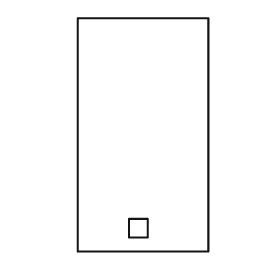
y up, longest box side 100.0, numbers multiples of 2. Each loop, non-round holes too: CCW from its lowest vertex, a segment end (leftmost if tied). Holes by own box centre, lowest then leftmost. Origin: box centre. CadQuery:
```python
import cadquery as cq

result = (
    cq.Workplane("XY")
    .moveTo(-28.0, -50.0)
    .lineTo(28.0, -50.0)
    .lineTo(28.0, 50.0)
    .lineTo(-28.0, 50.0)
    .close()
    .moveTo(-6.0, -44.0)
    .lineTo(2.0, -44.0)
    .lineTo(2.0, -36.0)
    .lineTo(-6.0, -36.0)
    .close()
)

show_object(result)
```